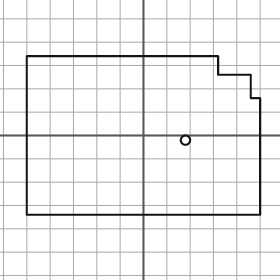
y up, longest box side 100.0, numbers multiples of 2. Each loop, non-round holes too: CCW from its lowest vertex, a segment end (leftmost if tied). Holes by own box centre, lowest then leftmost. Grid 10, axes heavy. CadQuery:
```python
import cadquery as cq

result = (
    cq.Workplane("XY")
    .moveTo(-50.0, -34.0)
    .lineTo(50.0, -34.0)
    .lineTo(50.0, 16.0)
    .lineTo(46.0, 16.0)
    .lineTo(46.0, 26.0)
    .lineTo(32.0, 26.0)
    .lineTo(32.0, 34.0)
    .lineTo(-50.0, 34.0)
    .close()
    .moveTo(18.0, -2.0)
    .circle(2.0)
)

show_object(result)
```